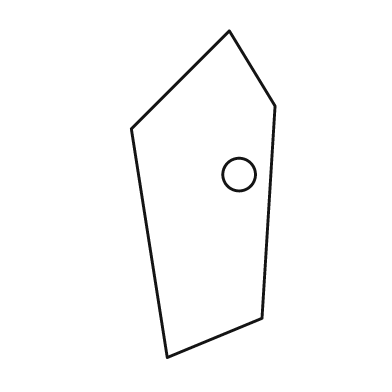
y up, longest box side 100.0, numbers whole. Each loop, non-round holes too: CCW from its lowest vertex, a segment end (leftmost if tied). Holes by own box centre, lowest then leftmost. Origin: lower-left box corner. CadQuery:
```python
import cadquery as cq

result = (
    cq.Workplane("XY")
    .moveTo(11.0, 0.0)
    .lineTo(40.0, 12.0)
    .lineTo(44.0, 77.0)
    .lineTo(30.0, 100.0)
    .lineTo(0.0, 70.0)
    .close()
    .moveTo(33.0, 56.0)
    .circle(5.0)
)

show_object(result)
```